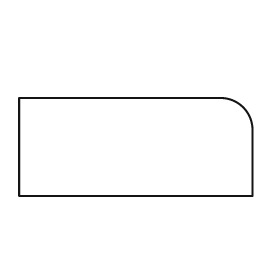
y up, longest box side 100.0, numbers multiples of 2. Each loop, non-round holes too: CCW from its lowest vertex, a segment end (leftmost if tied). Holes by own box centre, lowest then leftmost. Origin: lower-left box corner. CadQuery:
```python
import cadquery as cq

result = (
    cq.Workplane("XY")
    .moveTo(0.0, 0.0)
    .lineTo(100.0, 0.0)
    .lineTo(100.0, 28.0)
    .threePointArc((96.0, 38.0), (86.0, 42.0))
    .lineTo(0.0, 42.0)
    .close()
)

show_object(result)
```